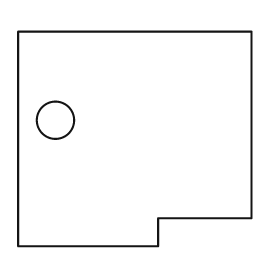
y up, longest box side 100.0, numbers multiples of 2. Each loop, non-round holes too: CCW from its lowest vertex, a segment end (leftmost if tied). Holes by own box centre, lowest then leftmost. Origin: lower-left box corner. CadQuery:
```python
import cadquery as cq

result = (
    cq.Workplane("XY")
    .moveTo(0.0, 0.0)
    .lineTo(60.0, 0.0)
    .lineTo(60.0, 12.0)
    .lineTo(100.0, 12.0)
    .lineTo(100.0, 92.0)
    .lineTo(0.0, 92.0)
    .close()
    .moveTo(16.0, 54.0)
    .circle(8.0)
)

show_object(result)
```